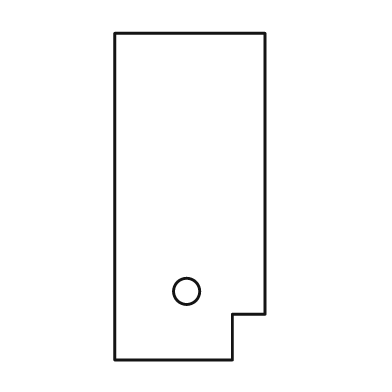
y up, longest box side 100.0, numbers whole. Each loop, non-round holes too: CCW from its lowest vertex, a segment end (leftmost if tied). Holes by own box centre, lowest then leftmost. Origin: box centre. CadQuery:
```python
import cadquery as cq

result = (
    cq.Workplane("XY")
    .moveTo(-23.0, -50.0)
    .lineTo(13.0, -50.0)
    .lineTo(13.0, -36.0)
    .lineTo(23.0, -36.0)
    .lineTo(23.0, 50.0)
    .lineTo(-23.0, 50.0)
    .close()
    .moveTo(-1.0, -29.0)
    .circle(4.0)
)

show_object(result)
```